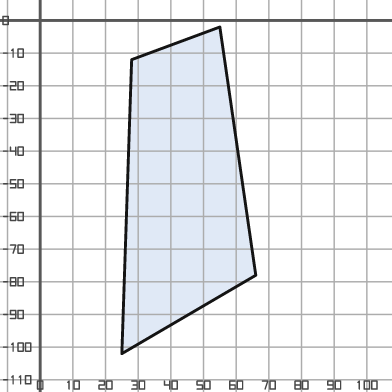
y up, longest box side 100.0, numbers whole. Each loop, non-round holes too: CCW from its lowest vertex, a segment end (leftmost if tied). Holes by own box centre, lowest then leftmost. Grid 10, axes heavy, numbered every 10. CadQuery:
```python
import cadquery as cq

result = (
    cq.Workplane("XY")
    .moveTo(25.0, -102.0)
    .lineTo(66.0, -78.0)
    .lineTo(55.0, -2.0)
    .lineTo(28.0, -12.0)
    .close()
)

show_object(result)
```